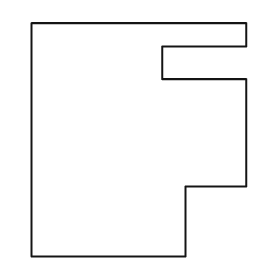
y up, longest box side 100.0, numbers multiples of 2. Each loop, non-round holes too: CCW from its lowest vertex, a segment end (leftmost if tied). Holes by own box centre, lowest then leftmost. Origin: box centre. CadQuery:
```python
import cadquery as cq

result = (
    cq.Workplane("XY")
    .moveTo(-46.0, -50.0)
    .lineTo(20.0, -50.0)
    .lineTo(20.0, -20.0)
    .lineTo(46.0, -20.0)
    .lineTo(46.0, 26.0)
    .lineTo(10.0, 26.0)
    .lineTo(10.0, 40.0)
    .lineTo(46.0, 40.0)
    .lineTo(46.0, 50.0)
    .lineTo(-46.0, 50.0)
    .close()
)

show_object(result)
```